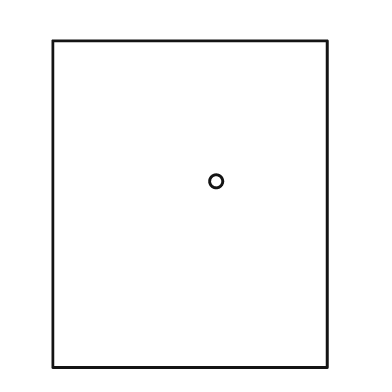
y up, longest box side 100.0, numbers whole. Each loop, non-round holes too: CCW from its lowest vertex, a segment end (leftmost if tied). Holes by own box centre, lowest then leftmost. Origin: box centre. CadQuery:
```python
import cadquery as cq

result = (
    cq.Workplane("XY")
    .moveTo(-42.0, -50.0)
    .lineTo(42.0, -50.0)
    .lineTo(42.0, 50.0)
    .lineTo(-42.0, 50.0)
    .close()
    .moveTo(8.0, 7.0)
    .circle(2.0)
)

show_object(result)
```